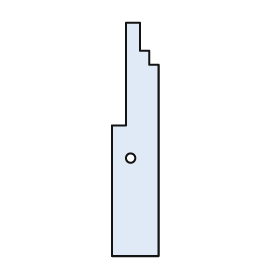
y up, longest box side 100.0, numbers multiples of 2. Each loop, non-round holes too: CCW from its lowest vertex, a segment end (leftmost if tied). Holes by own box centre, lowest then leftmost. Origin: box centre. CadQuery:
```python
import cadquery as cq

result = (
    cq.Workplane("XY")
    .moveTo(-10.0, -50.0)
    .lineTo(10.0, -50.0)
    .lineTo(10.0, 32.0)
    .lineTo(6.0, 32.0)
    .lineTo(6.0, 38.0)
    .lineTo(2.0, 38.0)
    .lineTo(2.0, 50.0)
    .lineTo(-4.0, 50.0)
    .lineTo(-4.0, 6.0)
    .lineTo(-10.0, 6.0)
    .close()
    .moveTo(-2.0, -8.0)
    .circle(2.0)
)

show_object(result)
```